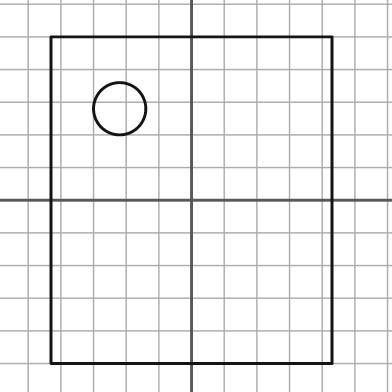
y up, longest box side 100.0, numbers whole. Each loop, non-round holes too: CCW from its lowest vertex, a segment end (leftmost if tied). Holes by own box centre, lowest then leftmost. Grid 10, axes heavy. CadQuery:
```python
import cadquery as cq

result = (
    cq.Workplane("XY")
    .moveTo(-43.0, -50.0)
    .lineTo(43.0, -50.0)
    .lineTo(43.0, 50.0)
    .lineTo(-43.0, 50.0)
    .close()
    .moveTo(-22.0, 28.0)
    .circle(8.0)
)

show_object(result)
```